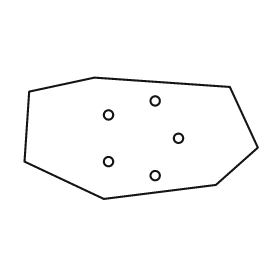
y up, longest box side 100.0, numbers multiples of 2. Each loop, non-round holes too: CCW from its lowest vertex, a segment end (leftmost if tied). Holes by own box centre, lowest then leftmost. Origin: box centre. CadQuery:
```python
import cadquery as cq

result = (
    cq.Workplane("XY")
    .moveTo(-16.0, -26.0)
    .lineTo(32.0, -20.0)
    .lineTo(50.0, -4.0)
    .lineTo(38.0, 22.0)
    .lineTo(-20.0, 26.0)
    .lineTo(-48.0, 20.0)
    .lineTo(-50.0, -10.0)
    .close()
    .moveTo(6.0, -16.0)
    .circle(2.0)
    .moveTo(-14.0, -10.0)
    .circle(2.0)
    .moveTo(16.0, 0.0)
    .circle(2.0)
    .moveTo(-14.0, 10.0)
    .circle(2.0)
    .moveTo(6.0, 16.0)
    .circle(2.0)
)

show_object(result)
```